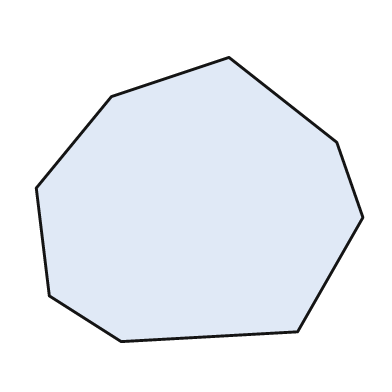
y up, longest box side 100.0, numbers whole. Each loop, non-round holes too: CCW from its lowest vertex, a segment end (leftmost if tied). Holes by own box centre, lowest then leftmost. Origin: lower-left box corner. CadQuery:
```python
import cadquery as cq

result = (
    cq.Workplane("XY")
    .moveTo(26.0, 0.0)
    .lineTo(80.0, 3.0)
    .lineTo(100.0, 38.0)
    .lineTo(92.0, 61.0)
    .lineTo(59.0, 87.0)
    .lineTo(23.0, 75.0)
    .lineTo(0.0, 47.0)
    .lineTo(4.0, 14.0)
    .close()
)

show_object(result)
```